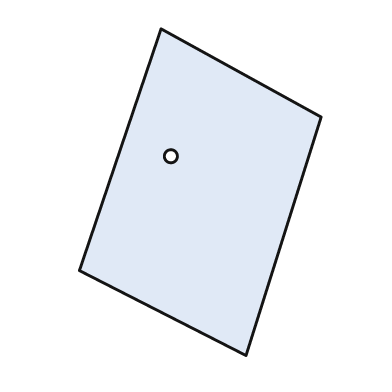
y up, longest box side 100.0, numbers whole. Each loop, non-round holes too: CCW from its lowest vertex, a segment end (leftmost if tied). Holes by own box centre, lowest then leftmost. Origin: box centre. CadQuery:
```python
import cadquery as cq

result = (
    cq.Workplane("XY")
    .moveTo(14.0, -50.0)
    .lineTo(37.0, 23.0)
    .lineTo(-12.0, 50.0)
    .lineTo(-37.0, -24.0)
    .close()
    .moveTo(-9.0, 11.0)
    .circle(2.0)
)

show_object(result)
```